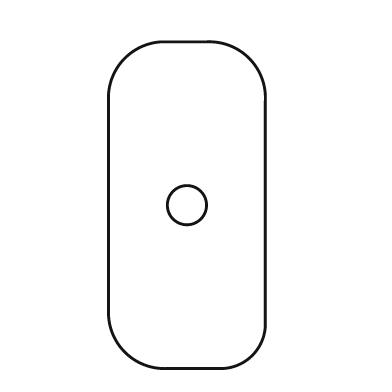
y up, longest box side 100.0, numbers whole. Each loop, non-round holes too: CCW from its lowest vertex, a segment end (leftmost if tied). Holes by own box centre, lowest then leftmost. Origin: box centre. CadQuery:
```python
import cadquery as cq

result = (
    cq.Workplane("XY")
    .moveTo(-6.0, -50.0)
    .lineTo(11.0, -50.0)
    .threePointArc((20.0, -46.0), (24.0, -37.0))
    .lineTo(24.0, 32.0)
    .threePointArc((19.0, 45.0), (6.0, 50.0))
    .lineTo(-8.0, 50.0)
    .threePointArc((-19.0, 45.0), (-24.0, 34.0))
    .lineTo(-24.0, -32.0)
    .threePointArc((-19.0, -45.0), (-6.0, -50.0))
    .close()
    .moveTo(0.0, 0.0)
    .circle(6.0)
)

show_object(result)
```